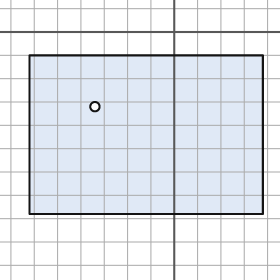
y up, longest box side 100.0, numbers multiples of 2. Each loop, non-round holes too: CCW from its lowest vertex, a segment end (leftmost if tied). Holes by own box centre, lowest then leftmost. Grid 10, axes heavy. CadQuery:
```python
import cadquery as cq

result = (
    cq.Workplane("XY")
    .moveTo(-62.0, -78.0)
    .lineTo(38.0, -78.0)
    .lineTo(38.0, -10.0)
    .lineTo(-62.0, -10.0)
    .close()
    .moveTo(-34.0, -32.0)
    .circle(2.0)
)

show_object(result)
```